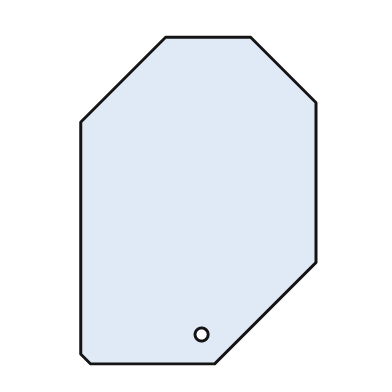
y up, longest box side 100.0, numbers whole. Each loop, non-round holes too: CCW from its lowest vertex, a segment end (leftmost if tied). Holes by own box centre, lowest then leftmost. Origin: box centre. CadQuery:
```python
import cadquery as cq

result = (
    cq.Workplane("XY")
    .moveTo(-33.0, -50.0)
    .lineTo(5.0, -50.0)
    .lineTo(36.0, -19.0)
    .lineTo(36.0, 30.0)
    .lineTo(16.0, 50.0)
    .lineTo(-10.0, 50.0)
    .lineTo(-36.0, 24.0)
    .lineTo(-36.0, -47.0)
    .close()
    .moveTo(1.0, -41.0)
    .circle(2.0)
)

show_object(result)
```